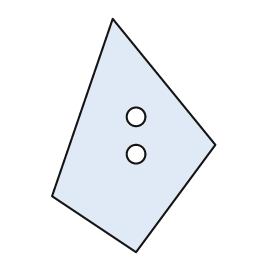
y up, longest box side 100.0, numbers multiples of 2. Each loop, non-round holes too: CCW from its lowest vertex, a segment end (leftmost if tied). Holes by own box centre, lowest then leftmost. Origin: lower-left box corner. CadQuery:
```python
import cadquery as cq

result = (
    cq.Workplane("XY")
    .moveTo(36.0, 0.0)
    .lineTo(70.0, 46.0)
    .lineTo(26.0, 100.0)
    .lineTo(0.0, 24.0)
    .close()
    .moveTo(36.0, 42.0)
    .circle(4.0)
    .moveTo(36.0, 58.0)
    .circle(4.0)
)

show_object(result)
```